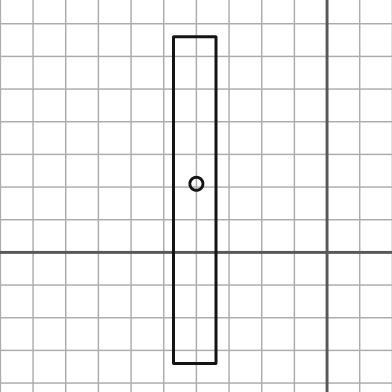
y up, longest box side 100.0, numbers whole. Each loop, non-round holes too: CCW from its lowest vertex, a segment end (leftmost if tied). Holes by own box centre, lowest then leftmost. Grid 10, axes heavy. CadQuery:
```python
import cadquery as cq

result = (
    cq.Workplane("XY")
    .moveTo(-47.0, -34.0)
    .lineTo(-34.0, -34.0)
    .lineTo(-34.0, 66.0)
    .lineTo(-47.0, 66.0)
    .close()
    .moveTo(-40.0, 21.0)
    .circle(2.0)
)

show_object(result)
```